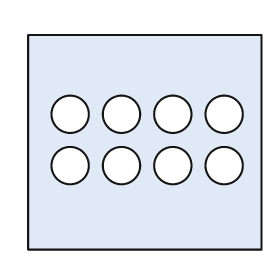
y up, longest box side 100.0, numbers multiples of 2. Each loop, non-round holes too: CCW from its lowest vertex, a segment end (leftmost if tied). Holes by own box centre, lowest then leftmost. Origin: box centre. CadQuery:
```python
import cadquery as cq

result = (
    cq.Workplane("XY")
    .moveTo(-50.0, -46.0)
    .lineTo(50.0, -46.0)
    .lineTo(50.0, 46.0)
    .lineTo(-50.0, 46.0)
    .close()
    .moveTo(-32.0, -10.0)
    .circle(8.0)
    .moveTo(-10.0, -10.0)
    .circle(8.0)
    .moveTo(12.0, -10.0)
    .circle(8.0)
    .moveTo(34.0, -10.0)
    .circle(8.0)
    .moveTo(-32.0, 12.0)
    .circle(8.0)
    .moveTo(-10.0, 12.0)
    .circle(8.0)
    .moveTo(12.0, 12.0)
    .circle(8.0)
    .moveTo(34.0, 12.0)
    .circle(8.0)
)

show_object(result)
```